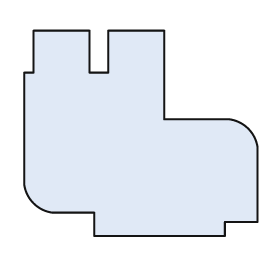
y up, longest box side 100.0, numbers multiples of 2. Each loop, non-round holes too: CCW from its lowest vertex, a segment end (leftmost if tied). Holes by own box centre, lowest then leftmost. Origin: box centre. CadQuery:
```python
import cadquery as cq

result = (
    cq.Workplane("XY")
    .moveTo(-20.0, -44.0)
    .lineTo(36.0, -44.0)
    .lineTo(36.0, -38.0)
    .lineTo(50.0, -38.0)
    .lineTo(50.0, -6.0)
    .threePointArc((46.0, 2.0), (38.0, 6.0))
    .lineTo(10.0, 6.0)
    .lineTo(10.0, 44.0)
    .lineTo(-14.0, 44.0)
    .lineTo(-14.0, 26.0)
    .lineTo(-22.0, 26.0)
    .lineTo(-22.0, 44.0)
    .lineTo(-46.0, 44.0)
    .lineTo(-46.0, 26.0)
    .lineTo(-50.0, 26.0)
    .lineTo(-50.0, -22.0)
    .threePointArc((-46.0, -30.0), (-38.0, -34.0))
    .lineTo(-20.0, -34.0)
    .close()
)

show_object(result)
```